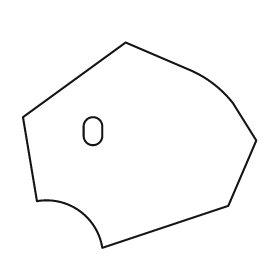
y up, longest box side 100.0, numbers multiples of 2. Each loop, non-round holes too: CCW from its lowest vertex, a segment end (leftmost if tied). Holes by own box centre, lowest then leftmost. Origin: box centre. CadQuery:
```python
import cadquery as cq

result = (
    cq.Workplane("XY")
    .moveTo(-16.0, -44.0)
    .lineTo(38.0, -26.0)
    .lineTo(50.0, 2.0)
    .lineTo(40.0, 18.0)
    .threePointArc((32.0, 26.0), (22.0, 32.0))
    .lineTo(-6.0, 44.0)
    .lineTo(-50.0, 12.0)
    .lineTo(-44.0, -24.0)
    .threePointArc((-26.0, -28.0), (-16.0, -44.0))
    .close()
    .moveTo(-24.0, 4.0)
    .threePointArc((-20.0, 0.0), (-16.0, 4.0))
    .lineTo(-16.0, 8.0)
    .threePointArc((-20.0, 12.0), (-24.0, 8.0))
    .close()
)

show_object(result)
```